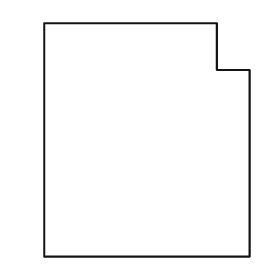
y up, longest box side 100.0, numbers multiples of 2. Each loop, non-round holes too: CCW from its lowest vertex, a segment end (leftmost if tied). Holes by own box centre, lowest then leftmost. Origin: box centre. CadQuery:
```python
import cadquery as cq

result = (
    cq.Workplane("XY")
    .moveTo(-44.0, -50.0)
    .lineTo(44.0, -50.0)
    .lineTo(44.0, 30.0)
    .lineTo(30.0, 30.0)
    .lineTo(30.0, 50.0)
    .lineTo(-44.0, 50.0)
    .close()
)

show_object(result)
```